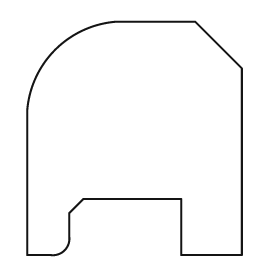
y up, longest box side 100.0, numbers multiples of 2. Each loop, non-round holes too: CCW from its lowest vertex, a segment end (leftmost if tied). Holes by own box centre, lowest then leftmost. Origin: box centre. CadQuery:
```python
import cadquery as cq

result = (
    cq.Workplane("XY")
    .moveTo(-46.0, -50.0)
    .lineTo(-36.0, -50.0)
    .threePointArc((-30.0, -48.0), (-28.0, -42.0))
    .lineTo(-28.0, -32.0)
    .lineTo(-22.0, -26.0)
    .lineTo(20.0, -26.0)
    .lineTo(20.0, -50.0)
    .lineTo(46.0, -50.0)
    .lineTo(46.0, 30.0)
    .lineTo(26.0, 50.0)
    .lineTo(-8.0, 50.0)
    .threePointArc((-34.0, 38.0), (-46.0, 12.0))
    .close()
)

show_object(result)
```